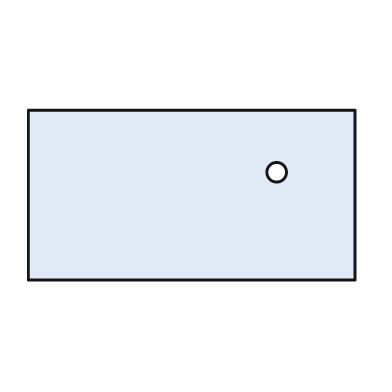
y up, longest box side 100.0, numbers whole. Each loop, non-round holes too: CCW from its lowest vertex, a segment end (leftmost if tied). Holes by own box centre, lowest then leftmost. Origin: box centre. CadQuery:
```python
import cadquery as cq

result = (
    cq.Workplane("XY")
    .moveTo(-50.0, -26.0)
    .lineTo(50.0, -26.0)
    .lineTo(50.0, 26.0)
    .lineTo(-50.0, 26.0)
    .close()
    .moveTo(26.0, 7.0)
    .circle(3.0)
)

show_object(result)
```